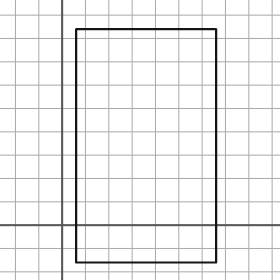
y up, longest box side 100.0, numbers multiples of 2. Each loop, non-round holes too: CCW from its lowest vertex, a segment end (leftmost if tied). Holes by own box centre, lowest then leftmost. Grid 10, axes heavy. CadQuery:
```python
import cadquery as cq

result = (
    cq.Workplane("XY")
    .moveTo(6.0, -16.0)
    .lineTo(66.0, -16.0)
    .lineTo(66.0, 84.0)
    .lineTo(6.0, 84.0)
    .close()
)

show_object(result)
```